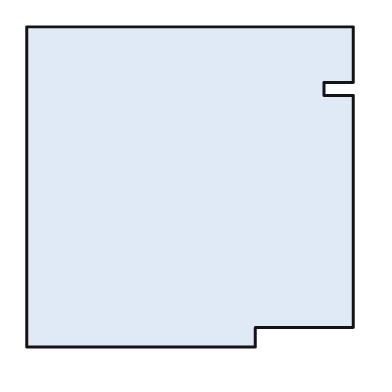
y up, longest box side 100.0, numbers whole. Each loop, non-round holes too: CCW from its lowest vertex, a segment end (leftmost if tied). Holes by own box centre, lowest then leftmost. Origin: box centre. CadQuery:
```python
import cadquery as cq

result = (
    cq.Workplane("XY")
    .moveTo(-50.0, -49.0)
    .lineTo(20.0, -49.0)
    .lineTo(20.0, -43.0)
    .lineTo(50.0, -43.0)
    .lineTo(50.0, 28.0)
    .lineTo(41.0, 28.0)
    .lineTo(41.0, 32.0)
    .lineTo(50.0, 32.0)
    .lineTo(50.0, 49.0)
    .lineTo(-50.0, 49.0)
    .close()
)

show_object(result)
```